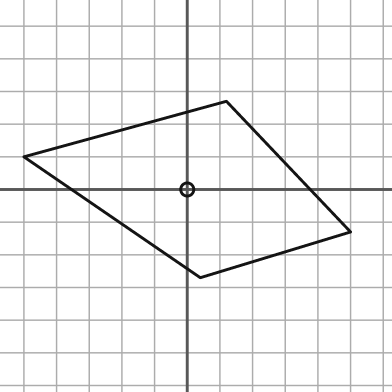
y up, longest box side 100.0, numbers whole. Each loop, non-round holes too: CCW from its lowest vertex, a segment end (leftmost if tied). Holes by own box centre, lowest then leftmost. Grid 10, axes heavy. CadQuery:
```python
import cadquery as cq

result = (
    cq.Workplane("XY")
    .moveTo(4.0, -27.0)
    .lineTo(50.0, -13.0)
    .lineTo(12.0, 27.0)
    .lineTo(-50.0, 10.0)
    .close()
    .moveTo(0.0, 0.0)
    .circle(2.0)
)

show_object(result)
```